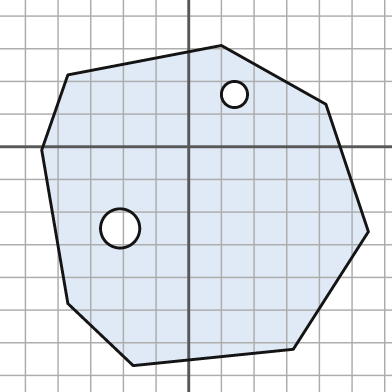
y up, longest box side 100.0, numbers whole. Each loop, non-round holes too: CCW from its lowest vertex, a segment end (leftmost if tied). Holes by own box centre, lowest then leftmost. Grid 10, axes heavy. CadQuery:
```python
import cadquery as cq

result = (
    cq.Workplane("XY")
    .moveTo(-17.0, -67.0)
    .lineTo(32.0, -62.0)
    .lineTo(55.0, -26.0)
    .lineTo(42.0, 13.0)
    .lineTo(10.0, 31.0)
    .lineTo(-37.0, 22.0)
    .lineTo(-45.0, -1.0)
    .lineTo(-37.0, -48.0)
    .close()
    .moveTo(-21.0, -25.0)
    .circle(6.0)
    .moveTo(14.0, 16.0)
    .circle(4.0)
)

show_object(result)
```